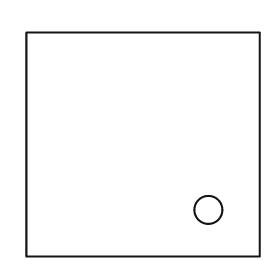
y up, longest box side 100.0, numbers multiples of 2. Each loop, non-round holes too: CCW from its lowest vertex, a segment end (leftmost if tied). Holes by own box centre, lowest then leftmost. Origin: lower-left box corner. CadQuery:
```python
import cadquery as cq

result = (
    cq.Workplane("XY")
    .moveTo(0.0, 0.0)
    .lineTo(100.0, 0.0)
    .lineTo(100.0, 96.0)
    .lineTo(0.0, 96.0)
    .close()
    .moveTo(78.0, 20.0)
    .circle(6.0)
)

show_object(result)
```